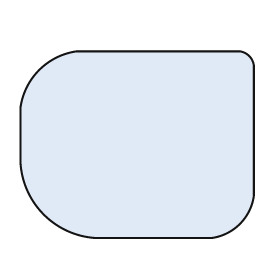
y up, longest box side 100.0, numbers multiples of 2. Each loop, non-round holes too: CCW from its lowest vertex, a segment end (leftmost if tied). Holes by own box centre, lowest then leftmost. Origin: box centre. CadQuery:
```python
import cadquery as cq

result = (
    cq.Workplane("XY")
    .moveTo(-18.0, -40.0)
    .lineTo(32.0, -40.0)
    .threePointArc((44.0, -34.0), (50.0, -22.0))
    .lineTo(50.0, 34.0)
    .threePointArc((48.0, 38.0), (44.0, 40.0))
    .lineTo(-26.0, 40.0)
    .threePointArc((-42.0, 32.0), (-50.0, 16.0))
    .lineTo(-50.0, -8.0)
    .threePointArc((-40.0, -30.0), (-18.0, -40.0))
    .close()
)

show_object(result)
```